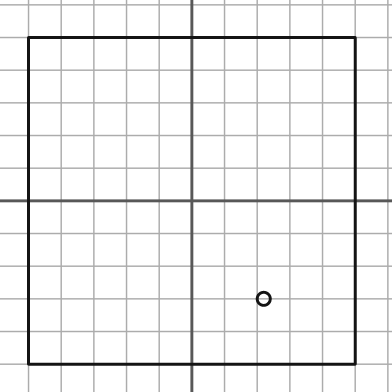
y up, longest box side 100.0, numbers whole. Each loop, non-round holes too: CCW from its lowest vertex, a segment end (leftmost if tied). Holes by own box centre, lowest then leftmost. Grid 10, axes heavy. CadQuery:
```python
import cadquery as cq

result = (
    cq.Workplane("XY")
    .moveTo(-50.0, -50.0)
    .lineTo(50.0, -50.0)
    .lineTo(50.0, 50.0)
    .lineTo(-50.0, 50.0)
    .close()
    .moveTo(22.0, -30.0)
    .circle(2.0)
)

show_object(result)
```